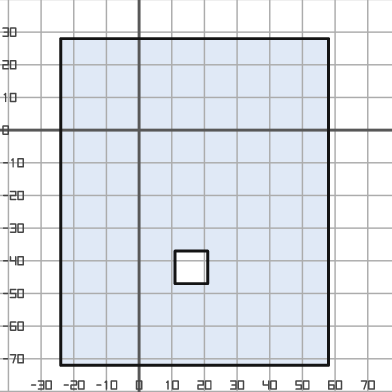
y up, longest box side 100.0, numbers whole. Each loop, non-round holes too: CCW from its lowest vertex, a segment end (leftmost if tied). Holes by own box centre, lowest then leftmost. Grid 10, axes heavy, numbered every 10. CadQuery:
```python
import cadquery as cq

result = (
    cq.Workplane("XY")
    .moveTo(-24.0, -72.0)
    .lineTo(58.0, -72.0)
    .lineTo(58.0, 28.0)
    .lineTo(-24.0, 28.0)
    .close()
    .moveTo(11.0, -47.0)
    .lineTo(21.0, -47.0)
    .lineTo(21.0, -37.0)
    .lineTo(11.0, -37.0)
    .close()
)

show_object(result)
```